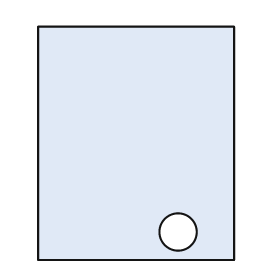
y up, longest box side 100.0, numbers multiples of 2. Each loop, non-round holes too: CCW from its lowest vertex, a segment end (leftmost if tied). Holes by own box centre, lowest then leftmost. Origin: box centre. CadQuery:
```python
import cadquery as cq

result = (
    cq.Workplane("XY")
    .moveTo(-42.0, -50.0)
    .lineTo(42.0, -50.0)
    .lineTo(42.0, 50.0)
    .lineTo(-42.0, 50.0)
    .close()
    .moveTo(18.0, -38.0)
    .circle(8.0)
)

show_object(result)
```